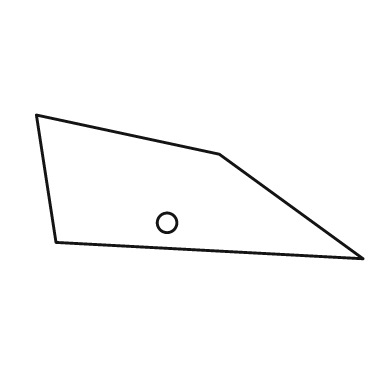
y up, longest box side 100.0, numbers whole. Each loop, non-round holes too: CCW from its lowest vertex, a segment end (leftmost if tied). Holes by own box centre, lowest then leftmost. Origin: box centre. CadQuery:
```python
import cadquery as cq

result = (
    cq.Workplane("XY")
    .moveTo(50.0, -22.0)
    .lineTo(6.0, 10.0)
    .lineTo(-50.0, 22.0)
    .lineTo(-44.0, -17.0)
    .close()
    .moveTo(-10.0, -11.0)
    .circle(3.0)
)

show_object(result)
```